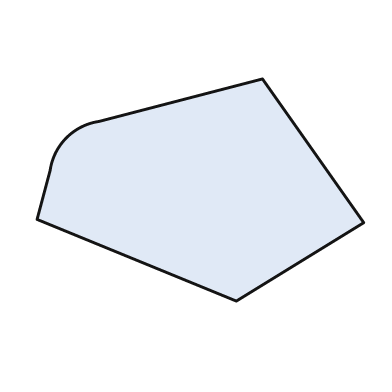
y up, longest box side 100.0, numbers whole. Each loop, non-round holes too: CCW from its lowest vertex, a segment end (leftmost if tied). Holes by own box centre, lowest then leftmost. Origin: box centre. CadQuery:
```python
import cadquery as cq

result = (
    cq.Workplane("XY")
    .moveTo(11.0, -34.0)
    .lineTo(50.0, -10.0)
    .lineTo(19.0, 34.0)
    .lineTo(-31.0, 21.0)
    .threePointArc((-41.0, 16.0), (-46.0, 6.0))
    .lineTo(-50.0, -9.0)
    .close()
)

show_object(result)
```